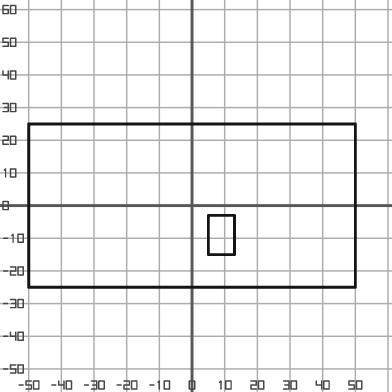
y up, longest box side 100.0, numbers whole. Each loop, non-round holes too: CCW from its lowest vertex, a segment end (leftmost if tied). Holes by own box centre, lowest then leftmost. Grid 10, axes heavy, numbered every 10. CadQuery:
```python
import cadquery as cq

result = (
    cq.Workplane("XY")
    .moveTo(-50.0, -25.0)
    .lineTo(50.0, -25.0)
    .lineTo(50.0, 25.0)
    .lineTo(-50.0, 25.0)
    .close()
    .moveTo(5.0, -15.0)
    .lineTo(13.0, -15.0)
    .lineTo(13.0, -3.0)
    .lineTo(5.0, -3.0)
    .close()
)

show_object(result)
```